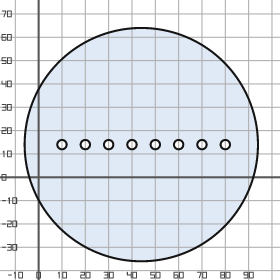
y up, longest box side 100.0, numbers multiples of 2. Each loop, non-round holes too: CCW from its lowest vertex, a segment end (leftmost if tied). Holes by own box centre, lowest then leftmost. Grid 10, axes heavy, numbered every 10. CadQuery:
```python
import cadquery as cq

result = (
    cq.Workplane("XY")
    .moveTo(44.0, 14.0)
    .circle(50.0)
    .moveTo(10.0, 14.0)
    .circle(2.0)
    .moveTo(20.0, 14.0)
    .circle(2.0)
    .moveTo(30.0, 14.0)
    .circle(2.0)
    .moveTo(40.0, 14.0)
    .circle(2.0)
    .moveTo(50.0, 14.0)
    .circle(2.0)
    .moveTo(60.0, 14.0)
    .circle(2.0)
    .moveTo(70.0, 14.0)
    .circle(2.0)
    .moveTo(80.0, 14.0)
    .circle(2.0)
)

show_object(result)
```